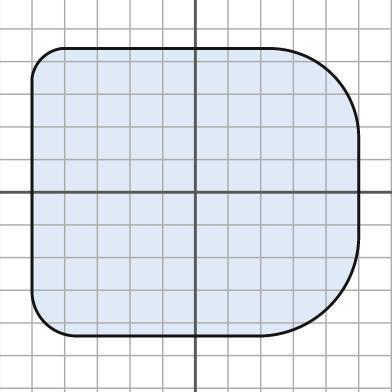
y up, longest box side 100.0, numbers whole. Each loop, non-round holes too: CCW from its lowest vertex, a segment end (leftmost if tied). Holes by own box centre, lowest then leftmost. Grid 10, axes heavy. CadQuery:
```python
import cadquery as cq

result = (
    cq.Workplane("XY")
    .moveTo(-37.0, -44.0)
    .lineTo(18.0, -44.0)
    .threePointArc((41.0, -35.0), (50.0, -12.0))
    .lineTo(50.0, 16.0)
    .threePointArc((42.0, 36.0), (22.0, 44.0))
    .lineTo(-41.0, 44.0)
    .threePointArc((-47.0, 41.0), (-50.0, 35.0))
    .lineTo(-50.0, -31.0)
    .threePointArc((-46.0, -40.0), (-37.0, -44.0))
    .close()
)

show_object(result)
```